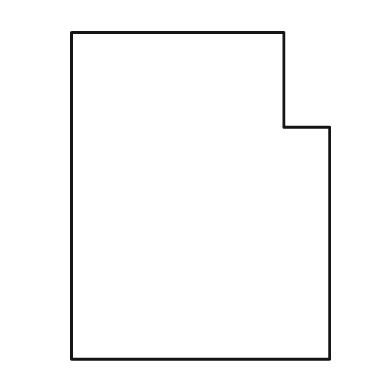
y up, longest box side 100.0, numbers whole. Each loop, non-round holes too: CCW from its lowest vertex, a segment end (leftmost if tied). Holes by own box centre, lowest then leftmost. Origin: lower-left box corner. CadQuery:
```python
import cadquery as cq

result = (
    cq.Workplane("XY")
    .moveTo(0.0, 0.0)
    .lineTo(79.0, 0.0)
    .lineTo(79.0, 71.0)
    .lineTo(65.0, 71.0)
    .lineTo(65.0, 100.0)
    .lineTo(0.0, 100.0)
    .close()
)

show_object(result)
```